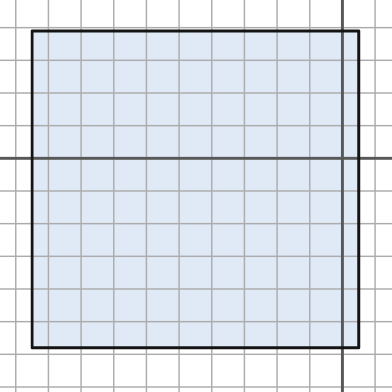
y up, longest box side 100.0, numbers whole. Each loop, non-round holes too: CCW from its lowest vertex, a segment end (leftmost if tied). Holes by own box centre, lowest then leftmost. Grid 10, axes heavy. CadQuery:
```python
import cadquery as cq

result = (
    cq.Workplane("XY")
    .moveTo(-95.0, -58.0)
    .lineTo(5.0, -58.0)
    .lineTo(5.0, 39.0)
    .lineTo(-95.0, 39.0)
    .close()
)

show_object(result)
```